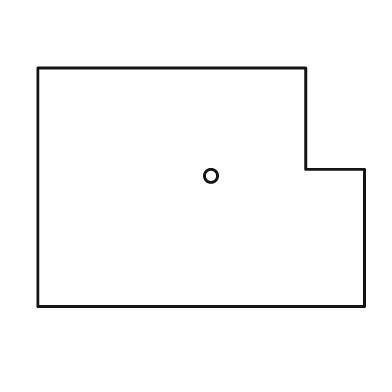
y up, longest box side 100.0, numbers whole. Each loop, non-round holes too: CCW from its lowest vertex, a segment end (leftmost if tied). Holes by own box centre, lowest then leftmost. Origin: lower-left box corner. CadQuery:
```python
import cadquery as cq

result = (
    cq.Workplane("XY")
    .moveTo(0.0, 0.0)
    .lineTo(100.0, 0.0)
    .lineTo(100.0, 42.0)
    .lineTo(82.0, 42.0)
    .lineTo(82.0, 73.0)
    .lineTo(0.0, 73.0)
    .close()
    .moveTo(53.0, 40.0)
    .circle(2.0)
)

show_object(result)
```